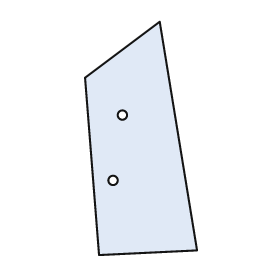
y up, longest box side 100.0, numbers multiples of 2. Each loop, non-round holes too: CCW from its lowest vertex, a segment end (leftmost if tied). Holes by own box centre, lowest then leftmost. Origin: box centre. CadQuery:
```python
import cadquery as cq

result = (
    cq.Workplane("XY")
    .moveTo(-18.0, -50.0)
    .lineTo(24.0, -48.0)
    .lineTo(8.0, 50.0)
    .lineTo(-24.0, 26.0)
    .close()
    .moveTo(-12.0, -18.0)
    .circle(2.0)
    .moveTo(-8.0, 10.0)
    .circle(2.0)
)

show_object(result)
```